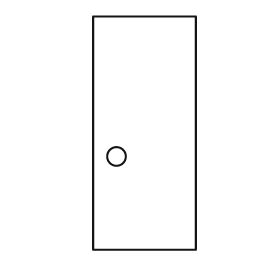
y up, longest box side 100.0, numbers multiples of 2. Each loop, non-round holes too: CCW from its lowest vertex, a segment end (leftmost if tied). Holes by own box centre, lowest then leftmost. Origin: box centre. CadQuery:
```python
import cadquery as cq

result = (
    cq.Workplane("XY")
    .moveTo(-22.0, -50.0)
    .lineTo(22.0, -50.0)
    .lineTo(22.0, 50.0)
    .lineTo(-22.0, 50.0)
    .close()
    .moveTo(-12.0, -10.0)
    .circle(4.0)
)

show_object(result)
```